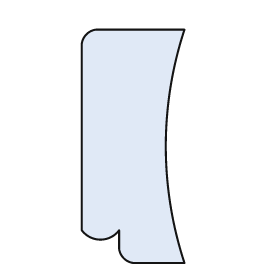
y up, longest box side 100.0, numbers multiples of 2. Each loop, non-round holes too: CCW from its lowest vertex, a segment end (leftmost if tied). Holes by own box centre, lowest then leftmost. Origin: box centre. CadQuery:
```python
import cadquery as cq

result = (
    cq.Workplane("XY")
    .moveTo(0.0, -50.0)
    .lineTo(22.0, -50.0)
    .threePointArc((14.0, 0.0), (22.0, 50.0))
    .lineTo(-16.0, 50.0)
    .threePointArc((-20.0, 48.0), (-22.0, 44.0))
    .lineTo(-22.0, -36.0)
    .threePointArc((-14.0, -40.0), (-6.0, -36.0))
    .lineTo(-6.0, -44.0)
    .threePointArc((-4.0, -48.0), (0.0, -50.0))
    .close()
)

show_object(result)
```